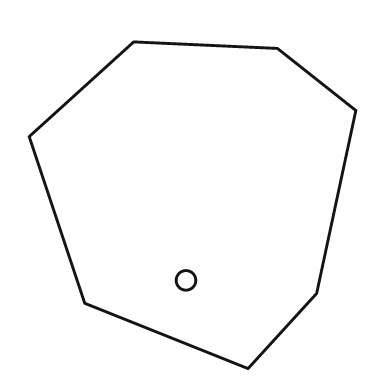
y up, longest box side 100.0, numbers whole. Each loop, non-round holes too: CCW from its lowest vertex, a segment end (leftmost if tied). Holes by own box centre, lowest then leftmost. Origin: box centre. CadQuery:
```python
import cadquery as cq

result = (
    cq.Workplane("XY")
    .moveTo(17.0, -50.0)
    .lineTo(38.0, -27.0)
    .lineTo(50.0, 29.0)
    .lineTo(26.0, 48.0)
    .lineTo(-18.0, 50.0)
    .lineTo(-50.0, 21.0)
    .lineTo(-33.0, -30.0)
    .close()
    .moveTo(-2.0, -23.0)
    .circle(3.0)
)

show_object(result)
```